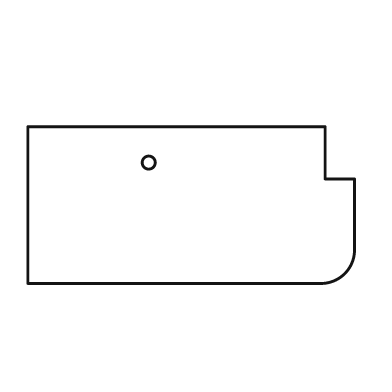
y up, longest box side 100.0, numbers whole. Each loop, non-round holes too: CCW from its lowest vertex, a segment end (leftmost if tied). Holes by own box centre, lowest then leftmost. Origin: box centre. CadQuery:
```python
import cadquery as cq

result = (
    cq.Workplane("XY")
    .moveTo(-50.0, -24.0)
    .lineTo(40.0, -24.0)
    .threePointArc((47.0, -21.0), (50.0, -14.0))
    .lineTo(50.0, 8.0)
    .lineTo(41.0, 8.0)
    .lineTo(41.0, 24.0)
    .lineTo(-50.0, 24.0)
    .close()
    .moveTo(-13.0, 13.0)
    .circle(2.0)
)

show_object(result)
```